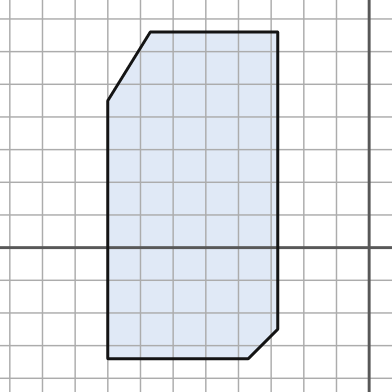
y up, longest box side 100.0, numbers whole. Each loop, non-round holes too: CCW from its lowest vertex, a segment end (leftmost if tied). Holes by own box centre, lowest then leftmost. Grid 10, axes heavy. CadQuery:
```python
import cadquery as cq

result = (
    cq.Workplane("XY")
    .moveTo(-80.0, -34.0)
    .lineTo(-37.0, -34.0)
    .lineTo(-28.0, -25.0)
    .lineTo(-28.0, 66.0)
    .lineTo(-67.0, 66.0)
    .lineTo(-80.0, 45.0)
    .close()
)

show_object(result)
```